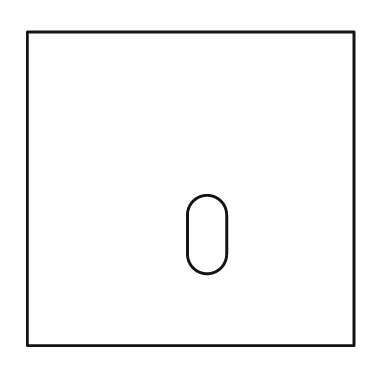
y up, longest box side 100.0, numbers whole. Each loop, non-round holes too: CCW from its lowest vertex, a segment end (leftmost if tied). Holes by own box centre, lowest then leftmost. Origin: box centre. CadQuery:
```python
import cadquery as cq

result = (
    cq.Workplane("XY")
    .moveTo(-50.0, -48.0)
    .lineTo(50.0, -48.0)
    .lineTo(50.0, 48.0)
    .lineTo(-50.0, 48.0)
    .close()
    .moveTo(-1.0, -20.0)
    .threePointArc((5.0, -26.0), (11.0, -20.0))
    .lineTo(11.0, -8.0)
    .threePointArc((5.0, -2.0), (-1.0, -8.0))
    .close()
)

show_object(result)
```